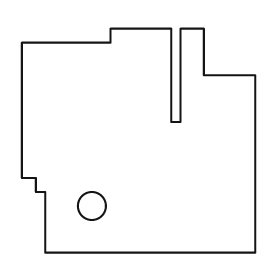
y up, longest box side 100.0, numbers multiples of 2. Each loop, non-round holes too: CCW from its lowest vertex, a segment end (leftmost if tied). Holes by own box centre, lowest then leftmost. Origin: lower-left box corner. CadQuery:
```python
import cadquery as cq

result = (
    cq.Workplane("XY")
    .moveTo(10.0, 0.0)
    .lineTo(100.0, 0.0)
    .lineTo(100.0, 76.0)
    .lineTo(78.0, 76.0)
    .lineTo(78.0, 96.0)
    .lineTo(68.0, 96.0)
    .lineTo(68.0, 56.0)
    .lineTo(64.0, 56.0)
    .lineTo(64.0, 96.0)
    .lineTo(38.0, 96.0)
    .lineTo(38.0, 90.0)
    .lineTo(0.0, 90.0)
    .lineTo(0.0, 32.0)
    .lineTo(6.0, 32.0)
    .lineTo(6.0, 26.0)
    .lineTo(10.0, 26.0)
    .close()
    .moveTo(30.0, 20.0)
    .circle(6.0)
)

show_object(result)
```